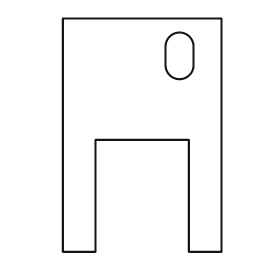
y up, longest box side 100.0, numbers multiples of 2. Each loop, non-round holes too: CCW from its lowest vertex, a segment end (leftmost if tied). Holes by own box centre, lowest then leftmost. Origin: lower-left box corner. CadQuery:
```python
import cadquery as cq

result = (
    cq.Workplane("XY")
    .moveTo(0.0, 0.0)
    .lineTo(14.0, 0.0)
    .lineTo(14.0, 48.0)
    .lineTo(54.0, 48.0)
    .lineTo(54.0, 0.0)
    .lineTo(68.0, 0.0)
    .lineTo(68.0, 100.0)
    .lineTo(0.0, 100.0)
    .close()
    .moveTo(44.0, 80.0)
    .threePointArc((50.0, 74.0), (56.0, 80.0))
    .lineTo(56.0, 88.0)
    .threePointArc((50.0, 94.0), (44.0, 88.0))
    .close()
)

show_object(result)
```